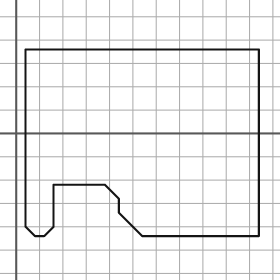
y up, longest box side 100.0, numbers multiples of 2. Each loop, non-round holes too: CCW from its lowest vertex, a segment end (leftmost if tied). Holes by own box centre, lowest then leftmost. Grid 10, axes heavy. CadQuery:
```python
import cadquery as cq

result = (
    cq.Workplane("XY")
    .moveTo(8.0, -44.0)
    .lineTo(12.0, -44.0)
    .lineTo(16.0, -40.0)
    .lineTo(16.0, -22.0)
    .lineTo(38.0, -22.0)
    .lineTo(44.0, -28.0)
    .lineTo(44.0, -34.0)
    .lineTo(54.0, -44.0)
    .lineTo(104.0, -44.0)
    .lineTo(104.0, 36.0)
    .lineTo(4.0, 36.0)
    .lineTo(4.0, -40.0)
    .close()
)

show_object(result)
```